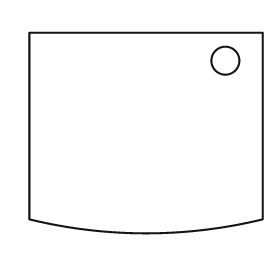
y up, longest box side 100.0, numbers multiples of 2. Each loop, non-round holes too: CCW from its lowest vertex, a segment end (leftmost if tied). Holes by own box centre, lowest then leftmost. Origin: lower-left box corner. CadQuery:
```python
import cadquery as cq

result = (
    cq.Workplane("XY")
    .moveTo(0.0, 6.0)
    .threePointArc((50.0, 0.0), (100.0, 6.0))
    .lineTo(100.0, 86.0)
    .lineTo(0.0, 86.0)
    .close()
    .moveTo(84.0, 74.0)
    .circle(6.0)
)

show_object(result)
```